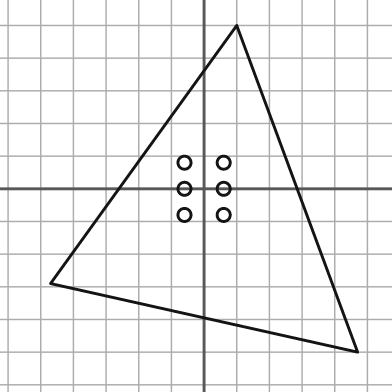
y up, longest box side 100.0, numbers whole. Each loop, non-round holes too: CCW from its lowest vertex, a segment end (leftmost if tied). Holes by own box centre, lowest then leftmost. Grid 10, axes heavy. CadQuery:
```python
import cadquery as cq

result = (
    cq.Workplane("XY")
    .moveTo(47.0, -50.0)
    .lineTo(10.0, 50.0)
    .lineTo(-47.0, -29.0)
    .close()
    .moveTo(-6.0, -8.0)
    .circle(2.0)
    .moveTo(6.0, -8.0)
    .circle(2.0)
    .moveTo(-6.0, 0.0)
    .circle(2.0)
    .moveTo(6.0, 0.0)
    .circle(2.0)
    .moveTo(-6.0, 8.0)
    .circle(2.0)
    .moveTo(6.0, 8.0)
    .circle(2.0)
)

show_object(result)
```